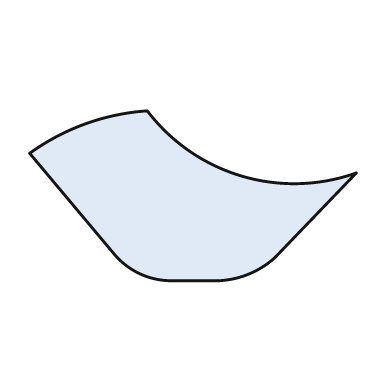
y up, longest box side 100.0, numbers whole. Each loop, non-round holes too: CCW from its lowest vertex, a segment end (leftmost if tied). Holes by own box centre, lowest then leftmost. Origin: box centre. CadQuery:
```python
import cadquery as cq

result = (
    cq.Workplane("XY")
    .moveTo(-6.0, -26.0)
    .lineTo(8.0, -26.0)
    .threePointArc((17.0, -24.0), (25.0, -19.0))
    .lineTo(50.0, 7.0)
    .threePointArc((15.0, 6.0), (-14.0, 26.0))
    .threePointArc((-33.0, 22.0), (-50.0, 13.0))
    .lineTo(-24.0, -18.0)
    .threePointArc((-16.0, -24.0), (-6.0, -26.0))
    .close()
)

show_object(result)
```